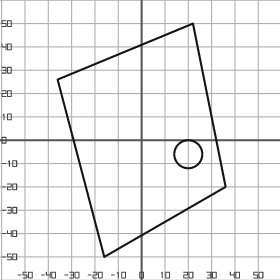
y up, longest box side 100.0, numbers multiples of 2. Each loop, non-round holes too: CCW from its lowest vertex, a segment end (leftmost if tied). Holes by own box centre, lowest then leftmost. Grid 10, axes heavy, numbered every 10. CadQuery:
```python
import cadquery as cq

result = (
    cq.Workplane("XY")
    .moveTo(-16.0, -50.0)
    .lineTo(36.0, -20.0)
    .lineTo(22.0, 50.0)
    .lineTo(-36.0, 26.0)
    .close()
    .moveTo(20.0, -6.0)
    .circle(6.0)
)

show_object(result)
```